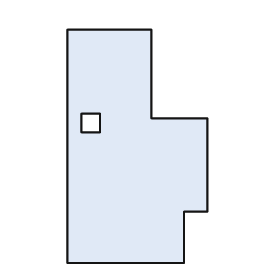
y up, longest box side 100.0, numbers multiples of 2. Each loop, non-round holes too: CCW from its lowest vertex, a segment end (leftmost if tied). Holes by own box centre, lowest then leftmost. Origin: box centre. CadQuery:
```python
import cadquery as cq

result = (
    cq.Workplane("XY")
    .moveTo(-30.0, -50.0)
    .lineTo(20.0, -50.0)
    .lineTo(20.0, -28.0)
    .lineTo(30.0, -28.0)
    .lineTo(30.0, 12.0)
    .lineTo(6.0, 12.0)
    .lineTo(6.0, 50.0)
    .lineTo(-30.0, 50.0)
    .close()
    .moveTo(-24.0, 6.0)
    .lineTo(-16.0, 6.0)
    .lineTo(-16.0, 14.0)
    .lineTo(-24.0, 14.0)
    .close()
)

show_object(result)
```